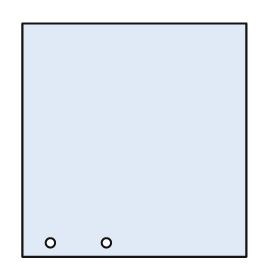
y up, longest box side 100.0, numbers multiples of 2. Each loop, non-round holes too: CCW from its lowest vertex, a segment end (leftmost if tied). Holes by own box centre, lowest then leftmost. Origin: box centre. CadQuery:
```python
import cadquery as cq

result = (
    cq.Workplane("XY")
    .moveTo(-48.0, -50.0)
    .lineTo(48.0, -50.0)
    .lineTo(48.0, 50.0)
    .lineTo(-48.0, 50.0)
    .close()
    .moveTo(-36.0, -44.0)
    .circle(2.0)
    .moveTo(-12.0, -44.0)
    .circle(2.0)
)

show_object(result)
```